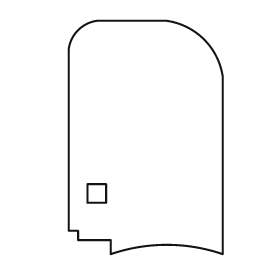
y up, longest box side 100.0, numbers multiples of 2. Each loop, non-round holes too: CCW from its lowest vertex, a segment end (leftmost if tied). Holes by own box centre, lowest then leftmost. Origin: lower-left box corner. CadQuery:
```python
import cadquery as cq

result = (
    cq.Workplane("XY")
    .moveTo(18.0, 0.0)
    .threePointArc((42.0, 4.0), (66.0, 0.0))
    .lineTo(66.0, 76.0)
    .threePointArc((58.0, 92.0), (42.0, 100.0))
    .lineTo(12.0, 100.0)
    .threePointArc((4.0, 96.0), (0.0, 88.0))
    .lineTo(0.0, 10.0)
    .lineTo(4.0, 10.0)
    .lineTo(4.0, 6.0)
    .lineTo(18.0, 6.0)
    .close()
    .moveTo(8.0, 22.0)
    .lineTo(16.0, 22.0)
    .lineTo(16.0, 30.0)
    .lineTo(8.0, 30.0)
    .close()
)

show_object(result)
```